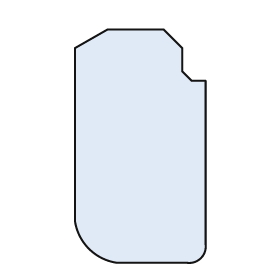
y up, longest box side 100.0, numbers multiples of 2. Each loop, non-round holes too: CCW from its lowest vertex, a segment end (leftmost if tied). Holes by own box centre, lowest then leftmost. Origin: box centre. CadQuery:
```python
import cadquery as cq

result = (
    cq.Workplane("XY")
    .moveTo(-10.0, -50.0)
    .lineTo(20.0, -50.0)
    .threePointArc((26.0, -48.0), (28.0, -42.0))
    .lineTo(28.0, 28.0)
    .lineTo(22.0, 28.0)
    .lineTo(18.0, 32.0)
    .lineTo(18.0, 42.0)
    .lineTo(10.0, 50.0)
    .lineTo(-14.0, 50.0)
    .lineTo(-28.0, 42.0)
    .lineTo(-28.0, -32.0)
    .threePointArc((-22.0, -44.0), (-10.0, -50.0))
    .close()
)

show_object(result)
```